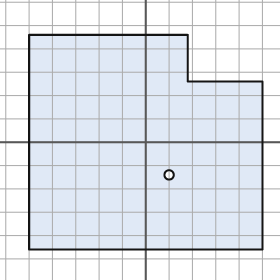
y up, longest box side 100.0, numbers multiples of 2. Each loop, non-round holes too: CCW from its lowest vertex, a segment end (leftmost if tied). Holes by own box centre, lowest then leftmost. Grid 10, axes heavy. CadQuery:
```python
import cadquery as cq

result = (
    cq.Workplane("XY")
    .moveTo(-50.0, -46.0)
    .lineTo(50.0, -46.0)
    .lineTo(50.0, 26.0)
    .lineTo(18.0, 26.0)
    .lineTo(18.0, 46.0)
    .lineTo(-50.0, 46.0)
    .close()
    .moveTo(10.0, -14.0)
    .circle(2.0)
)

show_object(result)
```